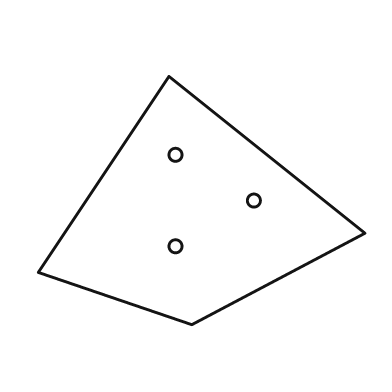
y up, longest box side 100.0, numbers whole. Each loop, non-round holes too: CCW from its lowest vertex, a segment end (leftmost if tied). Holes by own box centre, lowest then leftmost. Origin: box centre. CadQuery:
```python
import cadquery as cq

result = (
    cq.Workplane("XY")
    .moveTo(-3.0, -38.0)
    .lineTo(50.0, -10.0)
    .lineTo(-10.0, 38.0)
    .lineTo(-50.0, -22.0)
    .close()
    .moveTo(-8.0, -14.0)
    .circle(2.0)
    .moveTo(16.0, 0.0)
    .circle(2.0)
    .moveTo(-8.0, 14.0)
    .circle(2.0)
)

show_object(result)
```